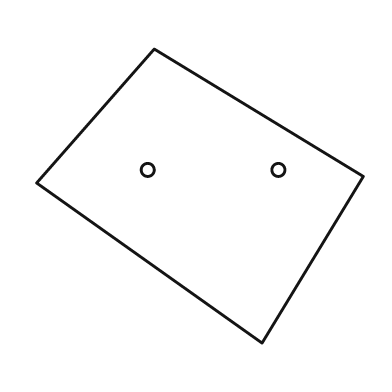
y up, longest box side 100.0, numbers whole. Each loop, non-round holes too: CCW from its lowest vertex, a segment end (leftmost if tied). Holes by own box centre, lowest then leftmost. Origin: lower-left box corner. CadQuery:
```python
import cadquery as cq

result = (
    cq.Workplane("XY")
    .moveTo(69.0, 0.0)
    .lineTo(100.0, 51.0)
    .lineTo(36.0, 90.0)
    .lineTo(0.0, 49.0)
    .close()
    .moveTo(34.0, 53.0)
    .circle(2.0)
    .moveTo(74.0, 53.0)
    .circle(2.0)
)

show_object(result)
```